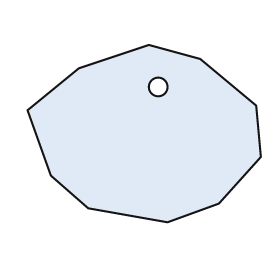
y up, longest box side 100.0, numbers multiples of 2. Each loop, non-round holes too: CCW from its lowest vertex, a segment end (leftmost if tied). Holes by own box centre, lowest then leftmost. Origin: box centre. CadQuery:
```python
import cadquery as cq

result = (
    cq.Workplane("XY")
    .moveTo(10.0, -38.0)
    .lineTo(32.0, -30.0)
    .lineTo(50.0, -10.0)
    .lineTo(48.0, 12.0)
    .lineTo(24.0, 32.0)
    .lineTo(2.0, 38.0)
    .lineTo(-28.0, 28.0)
    .lineTo(-50.0, 10.0)
    .lineTo(-40.0, -18.0)
    .lineTo(-24.0, -32.0)
    .close()
    .moveTo(6.0, 20.0)
    .circle(4.0)
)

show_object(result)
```